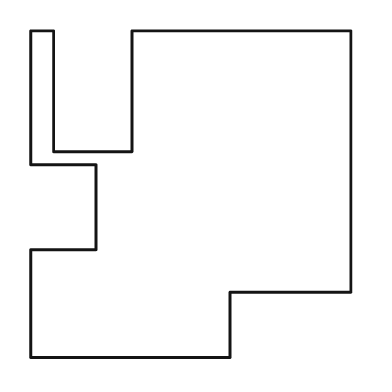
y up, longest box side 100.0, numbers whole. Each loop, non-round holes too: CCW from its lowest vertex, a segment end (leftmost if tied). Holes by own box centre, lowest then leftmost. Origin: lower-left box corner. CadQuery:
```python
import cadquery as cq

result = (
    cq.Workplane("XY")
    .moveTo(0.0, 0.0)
    .lineTo(61.0, 0.0)
    .lineTo(61.0, 20.0)
    .lineTo(98.0, 20.0)
    .lineTo(98.0, 100.0)
    .lineTo(31.0, 100.0)
    .lineTo(31.0, 63.0)
    .lineTo(7.0, 63.0)
    .lineTo(7.0, 100.0)
    .lineTo(0.0, 100.0)
    .lineTo(0.0, 59.0)
    .lineTo(20.0, 59.0)
    .lineTo(20.0, 33.0)
    .lineTo(0.0, 33.0)
    .close()
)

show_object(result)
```